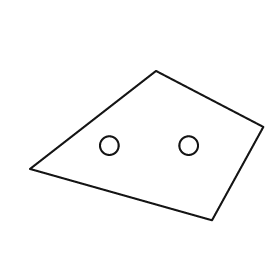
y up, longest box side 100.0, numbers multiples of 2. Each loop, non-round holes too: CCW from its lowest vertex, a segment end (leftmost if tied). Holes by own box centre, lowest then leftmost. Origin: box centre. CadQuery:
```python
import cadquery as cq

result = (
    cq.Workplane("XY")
    .moveTo(28.0, -32.0)
    .lineTo(50.0, 8.0)
    .lineTo(4.0, 32.0)
    .lineTo(-50.0, -10.0)
    .close()
    .moveTo(-16.0, 0.0)
    .circle(4.0)
    .moveTo(18.0, 0.0)
    .circle(4.0)
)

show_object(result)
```